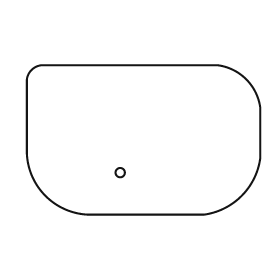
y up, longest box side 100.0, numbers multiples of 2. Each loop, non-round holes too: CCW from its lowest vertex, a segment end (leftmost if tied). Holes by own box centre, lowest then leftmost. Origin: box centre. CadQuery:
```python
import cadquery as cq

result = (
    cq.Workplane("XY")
    .moveTo(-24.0, -32.0)
    .lineTo(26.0, -32.0)
    .threePointArc((42.0, -24.0), (50.0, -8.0))
    .lineTo(50.0, 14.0)
    .threePointArc((44.0, 26.0), (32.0, 32.0))
    .lineTo(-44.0, 32.0)
    .threePointArc((-48.0, 30.0), (-50.0, 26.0))
    .lineTo(-50.0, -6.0)
    .threePointArc((-42.0, -24.0), (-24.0, -32.0))
    .close()
    .moveTo(-10.0, -14.0)
    .circle(2.0)
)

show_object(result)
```